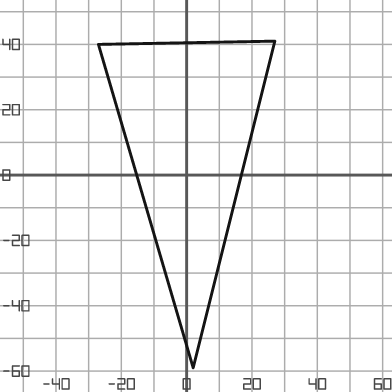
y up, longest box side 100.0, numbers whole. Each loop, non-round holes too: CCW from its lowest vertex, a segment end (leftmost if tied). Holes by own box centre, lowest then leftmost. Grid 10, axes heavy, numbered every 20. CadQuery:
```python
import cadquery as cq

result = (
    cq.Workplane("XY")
    .moveTo(2.0, -59.0)
    .lineTo(27.0, 41.0)
    .lineTo(-27.0, 40.0)
    .close()
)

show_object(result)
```